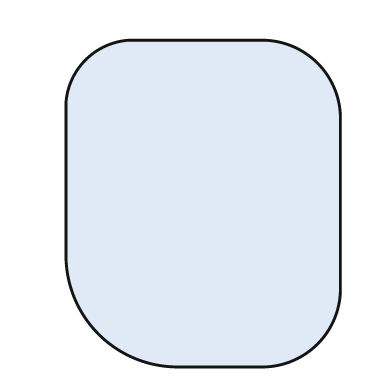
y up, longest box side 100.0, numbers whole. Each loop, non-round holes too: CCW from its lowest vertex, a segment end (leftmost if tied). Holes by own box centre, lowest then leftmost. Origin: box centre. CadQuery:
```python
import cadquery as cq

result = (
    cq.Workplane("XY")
    .moveTo(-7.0, -50.0)
    .lineTo(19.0, -50.0)
    .threePointArc((35.0, -43.0), (42.0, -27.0))
    .lineTo(42.0, 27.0)
    .threePointArc((35.0, 43.0), (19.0, 50.0))
    .lineTo(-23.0, 50.0)
    .threePointArc((-36.0, 44.0), (-42.0, 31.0))
    .lineTo(-42.0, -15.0)
    .threePointArc((-32.0, -40.0), (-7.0, -50.0))
    .close()
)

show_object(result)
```